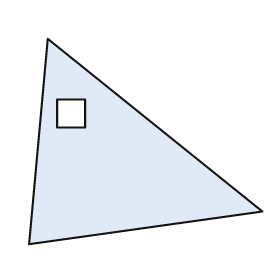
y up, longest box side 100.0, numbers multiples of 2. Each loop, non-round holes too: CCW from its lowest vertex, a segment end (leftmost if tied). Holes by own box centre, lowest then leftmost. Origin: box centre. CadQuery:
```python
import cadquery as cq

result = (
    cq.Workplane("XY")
    .moveTo(-50.0, -44.0)
    .lineTo(50.0, -30.0)
    .lineTo(-42.0, 44.0)
    .close()
    .moveTo(-38.0, 6.0)
    .lineTo(-26.0, 6.0)
    .lineTo(-26.0, 18.0)
    .lineTo(-38.0, 18.0)
    .close()
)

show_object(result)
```